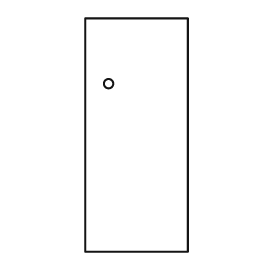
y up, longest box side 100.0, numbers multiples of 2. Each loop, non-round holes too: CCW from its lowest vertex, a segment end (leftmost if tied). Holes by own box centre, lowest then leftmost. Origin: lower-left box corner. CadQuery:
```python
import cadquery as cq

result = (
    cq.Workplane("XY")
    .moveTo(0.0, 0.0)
    .lineTo(44.0, 0.0)
    .lineTo(44.0, 100.0)
    .lineTo(0.0, 100.0)
    .close()
    .moveTo(10.0, 72.0)
    .circle(2.0)
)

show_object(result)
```